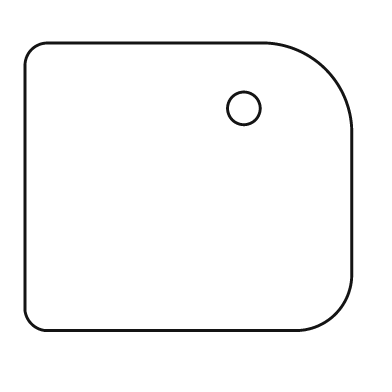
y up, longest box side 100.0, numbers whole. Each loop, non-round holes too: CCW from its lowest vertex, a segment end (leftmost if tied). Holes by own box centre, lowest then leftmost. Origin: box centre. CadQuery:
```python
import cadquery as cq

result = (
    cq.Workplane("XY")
    .moveTo(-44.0, -44.0)
    .lineTo(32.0, -44.0)
    .threePointArc((45.0, -39.0), (50.0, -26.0))
    .lineTo(50.0, 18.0)
    .threePointArc((42.0, 36.0), (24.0, 44.0))
    .lineTo(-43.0, 44.0)
    .threePointArc((-48.0, 42.0), (-50.0, 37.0))
    .lineTo(-50.0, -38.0)
    .threePointArc((-48.0, -42.0), (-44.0, -44.0))
    .close()
    .moveTo(17.0, 24.0)
    .circle(5.0)
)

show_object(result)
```